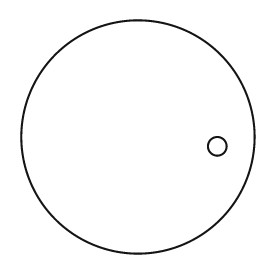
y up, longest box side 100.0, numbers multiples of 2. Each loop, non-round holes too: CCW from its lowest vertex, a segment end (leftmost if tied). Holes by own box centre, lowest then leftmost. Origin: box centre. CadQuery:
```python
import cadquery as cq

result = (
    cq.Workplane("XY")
    .moveTo(0.0, 0.0)
    .circle(50.0)
    .moveTo(34.0, -4.0)
    .circle(4.0)
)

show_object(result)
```